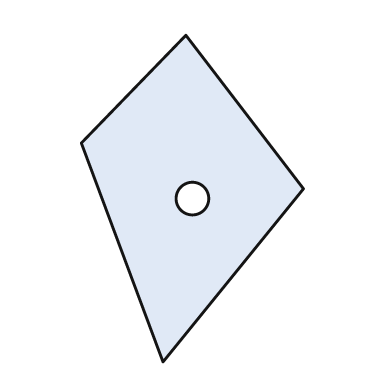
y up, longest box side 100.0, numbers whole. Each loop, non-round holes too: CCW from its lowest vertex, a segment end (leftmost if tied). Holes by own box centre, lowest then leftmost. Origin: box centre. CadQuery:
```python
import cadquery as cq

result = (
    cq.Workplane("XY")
    .moveTo(-9.0, -50.0)
    .lineTo(34.0, 3.0)
    .lineTo(-2.0, 50.0)
    .lineTo(-34.0, 17.0)
    .close()
    .moveTo(0.0, 0.0)
    .circle(5.0)
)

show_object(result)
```